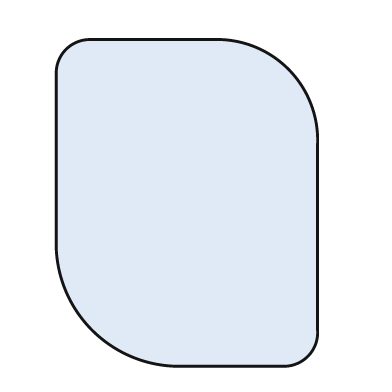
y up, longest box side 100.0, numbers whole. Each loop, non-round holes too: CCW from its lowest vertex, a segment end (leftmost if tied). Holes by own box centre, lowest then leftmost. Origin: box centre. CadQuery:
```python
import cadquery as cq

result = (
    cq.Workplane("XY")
    .moveTo(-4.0, -50.0)
    .lineTo(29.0, -50.0)
    .threePointArc((37.0, -47.0), (40.0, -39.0))
    .lineTo(40.0, 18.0)
    .threePointArc((31.0, 41.0), (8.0, 50.0))
    .lineTo(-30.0, 50.0)
    .threePointArc((-37.0, 47.0), (-40.0, 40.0))
    .lineTo(-40.0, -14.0)
    .threePointArc((-29.0, -39.0), (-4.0, -50.0))
    .close()
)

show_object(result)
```